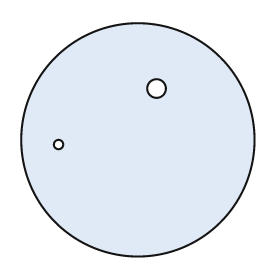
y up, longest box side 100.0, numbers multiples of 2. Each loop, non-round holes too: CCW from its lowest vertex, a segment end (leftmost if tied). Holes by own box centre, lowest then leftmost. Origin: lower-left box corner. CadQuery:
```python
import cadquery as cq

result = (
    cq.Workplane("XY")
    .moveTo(50.0, 50.0)
    .circle(50.0)
    .moveTo(16.0, 48.0)
    .circle(2.0)
    .moveTo(58.0, 72.0)
    .circle(4.0)
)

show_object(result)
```